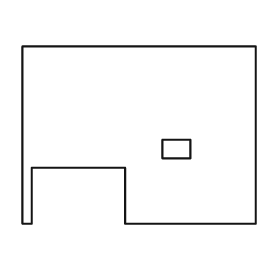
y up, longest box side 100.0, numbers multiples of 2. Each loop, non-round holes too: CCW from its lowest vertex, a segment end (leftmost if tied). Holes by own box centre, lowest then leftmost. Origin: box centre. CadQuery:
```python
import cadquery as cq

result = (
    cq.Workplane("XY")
    .moveTo(-50.0, -38.0)
    .lineTo(-46.0, -38.0)
    .lineTo(-46.0, -14.0)
    .lineTo(-6.0, -14.0)
    .lineTo(-6.0, -38.0)
    .lineTo(50.0, -38.0)
    .lineTo(50.0, 38.0)
    .lineTo(-50.0, 38.0)
    .close()
    .moveTo(10.0, -10.0)
    .lineTo(22.0, -10.0)
    .lineTo(22.0, -2.0)
    .lineTo(10.0, -2.0)
    .close()
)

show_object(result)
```